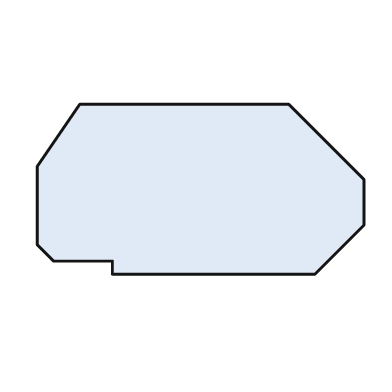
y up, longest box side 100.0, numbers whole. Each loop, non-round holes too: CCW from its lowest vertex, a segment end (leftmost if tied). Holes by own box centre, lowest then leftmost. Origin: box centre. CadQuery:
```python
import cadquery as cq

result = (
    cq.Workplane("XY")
    .moveTo(-27.0, -26.0)
    .lineTo(35.0, -26.0)
    .lineTo(50.0, -11.0)
    .lineTo(50.0, 3.0)
    .lineTo(27.0, 26.0)
    .lineTo(-37.0, 26.0)
    .lineTo(-50.0, 7.0)
    .lineTo(-50.0, -17.0)
    .lineTo(-45.0, -22.0)
    .lineTo(-27.0, -22.0)
    .close()
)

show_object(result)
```